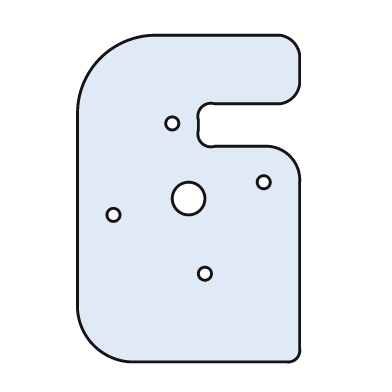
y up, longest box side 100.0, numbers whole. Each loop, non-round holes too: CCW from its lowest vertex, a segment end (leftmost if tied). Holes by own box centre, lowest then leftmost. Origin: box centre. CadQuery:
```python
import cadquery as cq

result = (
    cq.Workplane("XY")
    .moveTo(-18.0, -50.0)
    .lineTo(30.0, -50.0)
    .threePointArc((33.0, -49.0), (34.0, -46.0))
    .lineTo(34.0, 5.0)
    .threePointArc((31.0, 13.0), (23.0, 16.0))
    .lineTo(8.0, 16.0)
    .threePointArc((4.0, 17.0), (3.0, 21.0))
    .lineTo(3.0, 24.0)
    .threePointArc((4.0, 28.0), (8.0, 29.0))
    .lineTo(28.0, 29.0)
    .threePointArc((32.0, 31.0), (34.0, 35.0))
    .lineTo(34.0, 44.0)
    .threePointArc((32.0, 48.0), (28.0, 50.0))
    .lineTo(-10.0, 50.0)
    .threePointArc((-27.0, 43.0), (-34.0, 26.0))
    .lineTo(-34.0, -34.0)
    .threePointArc((-29.0, -45.0), (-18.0, -50.0))
    .close()
    .moveTo(5.0, -23.0)
    .circle(2.0)
    .moveTo(-23.0, -5.0)
    .circle(2.0)
    .moveTo(0.0, 0.0)
    .circle(5.0)
    .moveTo(23.0, 5.0)
    .circle(2.0)
    .moveTo(-5.0, 23.0)
    .circle(2.0)
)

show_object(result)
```